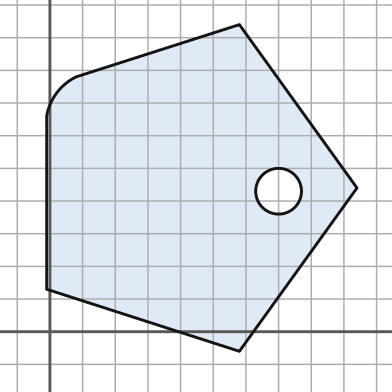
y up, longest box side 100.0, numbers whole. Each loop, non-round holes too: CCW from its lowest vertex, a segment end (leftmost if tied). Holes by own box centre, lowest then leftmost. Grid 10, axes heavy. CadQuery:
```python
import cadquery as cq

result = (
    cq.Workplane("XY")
    .moveTo(58.0, -6.0)
    .lineTo(94.0, 44.0)
    .lineTo(58.0, 94.0)
    .lineTo(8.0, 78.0)
    .threePointArc((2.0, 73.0), (-1.0, 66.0))
    .lineTo(-1.0, 13.0)
    .close()
    .moveTo(70.0, 43.0)
    .circle(7.0)
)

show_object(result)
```